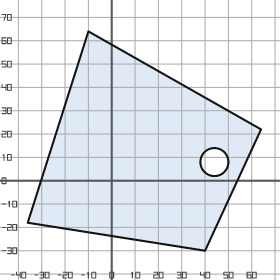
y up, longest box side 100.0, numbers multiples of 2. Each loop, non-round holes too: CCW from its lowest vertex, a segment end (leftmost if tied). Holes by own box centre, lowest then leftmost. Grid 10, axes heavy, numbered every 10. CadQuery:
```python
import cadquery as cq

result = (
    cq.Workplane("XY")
    .moveTo(40.0, -30.0)
    .lineTo(64.0, 22.0)
    .lineTo(-10.0, 64.0)
    .lineTo(-36.0, -18.0)
    .close()
    .moveTo(44.0, 8.0)
    .circle(6.0)
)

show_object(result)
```